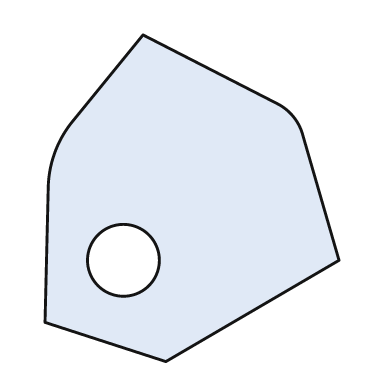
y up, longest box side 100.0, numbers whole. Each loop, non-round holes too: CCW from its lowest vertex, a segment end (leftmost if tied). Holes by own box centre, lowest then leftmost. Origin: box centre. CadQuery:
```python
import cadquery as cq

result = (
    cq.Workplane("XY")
    .moveTo(-8.0, -50.0)
    .lineTo(45.0, -19.0)
    .lineTo(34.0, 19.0)
    .threePointArc((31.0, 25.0), (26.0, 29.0))
    .lineTo(-15.0, 50.0)
    .lineTo(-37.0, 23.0)
    .threePointArc((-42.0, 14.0), (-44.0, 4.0))
    .lineTo(-45.0, -38.0)
    .close()
    .moveTo(-21.0, -19.0)
    .circle(11.0)
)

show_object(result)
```